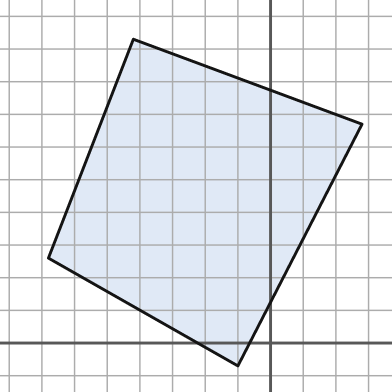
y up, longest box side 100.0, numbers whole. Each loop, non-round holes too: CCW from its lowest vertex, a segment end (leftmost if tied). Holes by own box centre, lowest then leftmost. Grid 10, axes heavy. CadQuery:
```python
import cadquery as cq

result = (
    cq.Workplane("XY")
    .moveTo(-10.0, -7.0)
    .lineTo(28.0, 67.0)
    .lineTo(-42.0, 93.0)
    .lineTo(-68.0, 26.0)
    .close()
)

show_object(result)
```